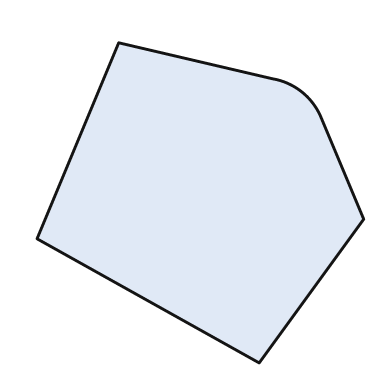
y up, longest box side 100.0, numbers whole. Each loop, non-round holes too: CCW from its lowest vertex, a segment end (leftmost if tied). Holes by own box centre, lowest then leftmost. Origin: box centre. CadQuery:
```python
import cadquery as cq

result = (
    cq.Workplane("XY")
    .moveTo(18.0, -49.0)
    .lineTo(50.0, -5.0)
    .lineTo(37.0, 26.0)
    .threePointArc((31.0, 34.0), (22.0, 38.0))
    .lineTo(-25.0, 49.0)
    .lineTo(-50.0, -11.0)
    .close()
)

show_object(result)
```